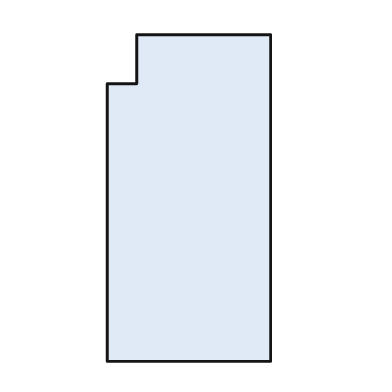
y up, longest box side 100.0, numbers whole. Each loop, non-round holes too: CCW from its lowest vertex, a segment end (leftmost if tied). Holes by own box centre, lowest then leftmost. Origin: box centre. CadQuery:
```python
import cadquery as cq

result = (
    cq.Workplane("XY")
    .moveTo(-25.0, -50.0)
    .lineTo(25.0, -50.0)
    .lineTo(25.0, 50.0)
    .lineTo(-16.0, 50.0)
    .lineTo(-16.0, 35.0)
    .lineTo(-25.0, 35.0)
    .close()
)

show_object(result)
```